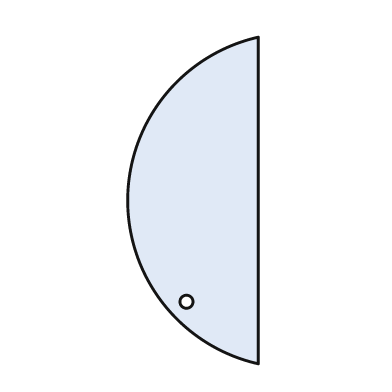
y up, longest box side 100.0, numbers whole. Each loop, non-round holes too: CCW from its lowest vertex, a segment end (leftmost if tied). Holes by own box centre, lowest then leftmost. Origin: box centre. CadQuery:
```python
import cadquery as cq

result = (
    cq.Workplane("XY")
    .moveTo(20.0, -50.0)
    .lineTo(20.0, 50.0)
    .threePointArc((-20.0, 0.0), (20.0, -50.0))
    .close()
    .moveTo(-2.0, -31.0)
    .circle(2.0)
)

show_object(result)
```